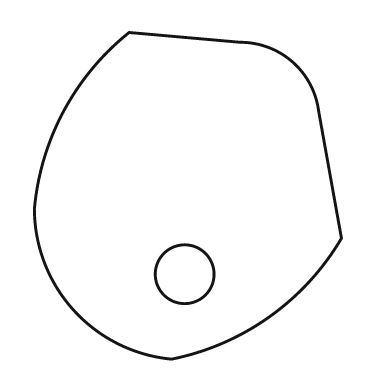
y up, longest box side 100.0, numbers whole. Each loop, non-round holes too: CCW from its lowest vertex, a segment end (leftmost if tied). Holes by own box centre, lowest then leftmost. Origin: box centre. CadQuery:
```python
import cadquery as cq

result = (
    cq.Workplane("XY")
    .moveTo(-5.0, -50.0)
    .threePointArc((25.0, -37.0), (47.0, -13.0))
    .lineTo(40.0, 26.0)
    .threePointArc((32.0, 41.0), (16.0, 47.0))
    .lineTo(-18.0, 50.0)
    .threePointArc((-38.0, 26.0), (-47.0, -4.0))
    .threePointArc((-35.0, -35.0), (-5.0, -50.0))
    .close()
    .moveTo(-1.0, -24.0)
    .circle(9.0)
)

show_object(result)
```